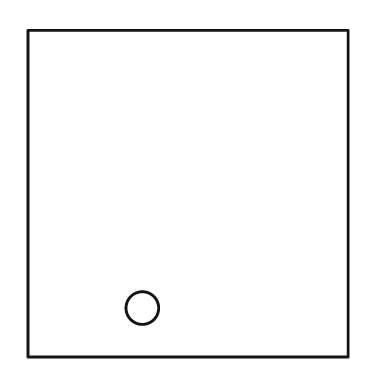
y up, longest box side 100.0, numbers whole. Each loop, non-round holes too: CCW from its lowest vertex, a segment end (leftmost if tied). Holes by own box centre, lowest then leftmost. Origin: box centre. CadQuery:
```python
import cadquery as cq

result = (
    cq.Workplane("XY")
    .moveTo(-49.0, -50.0)
    .lineTo(49.0, -50.0)
    .lineTo(49.0, 50.0)
    .lineTo(-49.0, 50.0)
    .close()
    .moveTo(-14.0, -35.0)
    .circle(5.0)
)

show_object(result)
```